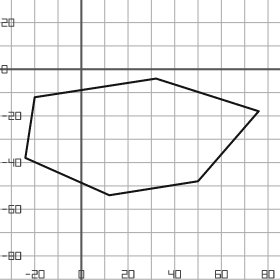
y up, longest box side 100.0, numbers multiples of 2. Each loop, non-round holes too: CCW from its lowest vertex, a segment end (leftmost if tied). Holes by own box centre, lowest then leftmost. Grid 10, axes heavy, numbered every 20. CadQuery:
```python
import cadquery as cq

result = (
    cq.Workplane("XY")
    .moveTo(12.0, -54.0)
    .lineTo(50.0, -48.0)
    .lineTo(76.0, -18.0)
    .lineTo(32.0, -4.0)
    .lineTo(-20.0, -12.0)
    .lineTo(-24.0, -38.0)
    .close()
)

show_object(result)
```